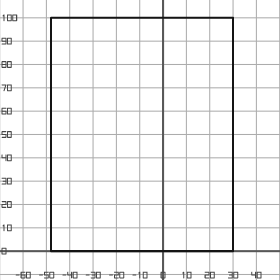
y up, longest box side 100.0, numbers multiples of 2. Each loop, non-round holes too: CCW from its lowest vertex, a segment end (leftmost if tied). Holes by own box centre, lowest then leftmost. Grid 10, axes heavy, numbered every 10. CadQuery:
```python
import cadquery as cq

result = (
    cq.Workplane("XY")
    .moveTo(-48.0, 0.0)
    .lineTo(30.0, 0.0)
    .lineTo(30.0, 100.0)
    .lineTo(-48.0, 100.0)
    .close()
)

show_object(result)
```